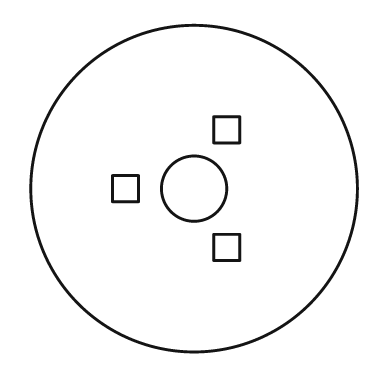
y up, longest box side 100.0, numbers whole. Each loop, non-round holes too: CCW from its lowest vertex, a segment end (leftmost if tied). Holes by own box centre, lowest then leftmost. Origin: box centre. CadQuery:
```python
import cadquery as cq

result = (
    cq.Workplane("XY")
    .moveTo(0.0, 0.0)
    .circle(50.0)
    .moveTo(6.0, -22.0)
    .lineTo(14.0, -22.0)
    .lineTo(14.0, -14.0)
    .lineTo(6.0, -14.0)
    .close()
    .moveTo(-25.0, -4.0)
    .lineTo(-17.0, -4.0)
    .lineTo(-17.0, 4.0)
    .lineTo(-25.0, 4.0)
    .close()
    .moveTo(0.0, 0.0)
    .circle(10.0)
    .moveTo(6.0, 14.0)
    .lineTo(14.0, 14.0)
    .lineTo(14.0, 22.0)
    .lineTo(6.0, 22.0)
    .close()
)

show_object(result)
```